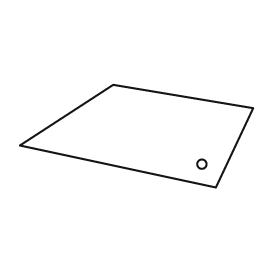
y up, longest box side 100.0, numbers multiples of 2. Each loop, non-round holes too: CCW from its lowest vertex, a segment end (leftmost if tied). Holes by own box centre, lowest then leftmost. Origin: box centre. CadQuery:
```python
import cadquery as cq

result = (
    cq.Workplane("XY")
    .moveTo(34.0, -22.0)
    .lineTo(50.0, 12.0)
    .lineTo(-10.0, 22.0)
    .lineTo(-50.0, -4.0)
    .close()
    .moveTo(28.0, -12.0)
    .circle(2.0)
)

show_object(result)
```